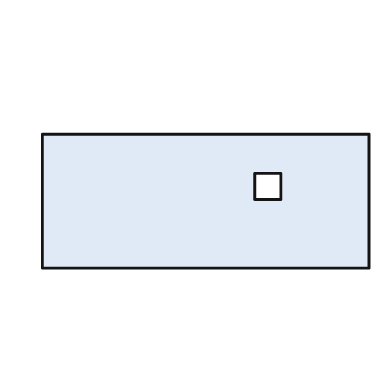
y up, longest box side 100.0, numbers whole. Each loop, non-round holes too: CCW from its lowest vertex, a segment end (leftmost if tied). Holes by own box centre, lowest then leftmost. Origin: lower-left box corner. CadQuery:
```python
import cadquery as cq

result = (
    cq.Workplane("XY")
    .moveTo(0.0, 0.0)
    .lineTo(100.0, 0.0)
    .lineTo(100.0, 41.0)
    .lineTo(0.0, 41.0)
    .close()
    .moveTo(65.0, 21.0)
    .lineTo(73.0, 21.0)
    .lineTo(73.0, 29.0)
    .lineTo(65.0, 29.0)
    .close()
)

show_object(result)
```